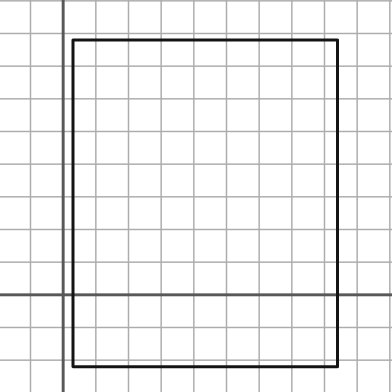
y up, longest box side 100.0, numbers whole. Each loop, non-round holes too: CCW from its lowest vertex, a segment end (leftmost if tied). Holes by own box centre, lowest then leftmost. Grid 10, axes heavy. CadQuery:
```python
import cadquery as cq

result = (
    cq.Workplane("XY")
    .moveTo(3.0, -22.0)
    .lineTo(84.0, -22.0)
    .lineTo(84.0, 78.0)
    .lineTo(3.0, 78.0)
    .close()
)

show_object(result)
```